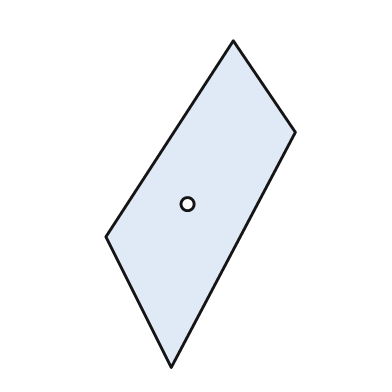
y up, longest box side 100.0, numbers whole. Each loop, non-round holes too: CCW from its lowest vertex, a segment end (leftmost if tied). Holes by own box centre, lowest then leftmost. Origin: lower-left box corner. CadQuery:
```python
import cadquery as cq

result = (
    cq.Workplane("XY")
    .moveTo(20.0, 0.0)
    .lineTo(58.0, 72.0)
    .lineTo(39.0, 100.0)
    .lineTo(0.0, 40.0)
    .close()
    .moveTo(25.0, 50.0)
    .circle(2.0)
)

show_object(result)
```